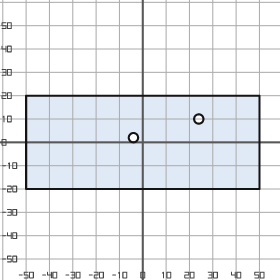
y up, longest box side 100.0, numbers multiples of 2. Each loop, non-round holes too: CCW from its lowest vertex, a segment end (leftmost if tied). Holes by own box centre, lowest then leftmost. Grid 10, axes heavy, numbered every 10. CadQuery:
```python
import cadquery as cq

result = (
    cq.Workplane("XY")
    .moveTo(-50.0, -20.0)
    .lineTo(50.0, -20.0)
    .lineTo(50.0, 20.0)
    .lineTo(-50.0, 20.0)
    .close()
    .moveTo(-4.0, 2.0)
    .circle(2.0)
    .moveTo(24.0, 10.0)
    .circle(2.0)
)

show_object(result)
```